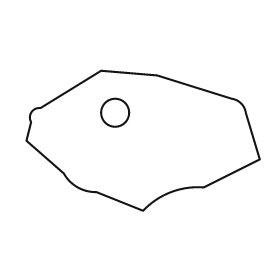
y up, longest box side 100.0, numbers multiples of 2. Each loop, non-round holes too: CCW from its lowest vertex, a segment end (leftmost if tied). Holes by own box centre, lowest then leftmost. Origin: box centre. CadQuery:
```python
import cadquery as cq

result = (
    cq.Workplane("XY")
    .moveTo(0.0, -30.0)
    .threePointArc((12.0, -22.0), (26.0, -20.0))
    .lineTo(50.0, -8.0)
    .lineTo(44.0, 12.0)
    .threePointArc((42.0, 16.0), (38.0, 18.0))
    .lineTo(6.0, 28.0)
    .lineTo(-18.0, 30.0)
    .lineTo(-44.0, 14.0)
    .threePointArc((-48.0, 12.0), (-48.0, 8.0))
    .lineTo(-50.0, 0.0)
    .lineTo(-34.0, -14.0)
    .threePointArc((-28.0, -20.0), (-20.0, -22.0))
    .close()
    .moveTo(-12.0, 12.0)
    .circle(6.0)
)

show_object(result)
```